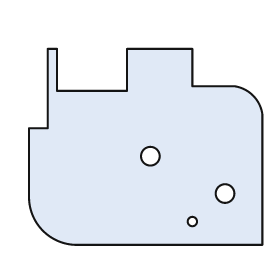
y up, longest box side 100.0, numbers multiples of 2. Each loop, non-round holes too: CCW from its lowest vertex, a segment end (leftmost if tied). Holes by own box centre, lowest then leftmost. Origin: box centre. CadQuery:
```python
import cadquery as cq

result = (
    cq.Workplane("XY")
    .moveTo(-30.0, -42.0)
    .lineTo(50.0, -42.0)
    .lineTo(50.0, 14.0)
    .threePointArc((46.0, 22.0), (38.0, 26.0))
    .lineTo(20.0, 26.0)
    .lineTo(20.0, 42.0)
    .lineTo(-8.0, 42.0)
    .lineTo(-8.0, 24.0)
    .lineTo(-38.0, 24.0)
    .lineTo(-38.0, 42.0)
    .lineTo(-42.0, 42.0)
    .lineTo(-42.0, 8.0)
    .lineTo(-50.0, 8.0)
    .lineTo(-50.0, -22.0)
    .threePointArc((-44.0, -36.0), (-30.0, -42.0))
    .close()
    .moveTo(20.0, -32.0)
    .circle(2.0)
    .moveTo(34.0, -20.0)
    .circle(4.0)
    .moveTo(2.0, -4.0)
    .circle(4.0)
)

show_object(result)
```